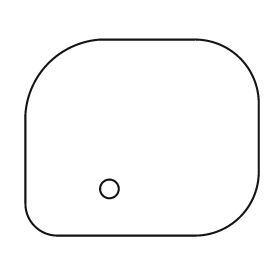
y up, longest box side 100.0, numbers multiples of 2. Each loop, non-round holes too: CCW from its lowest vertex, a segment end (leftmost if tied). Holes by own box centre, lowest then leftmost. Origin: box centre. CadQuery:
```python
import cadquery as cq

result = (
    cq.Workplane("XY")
    .moveTo(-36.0, -42.0)
    .lineTo(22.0, -42.0)
    .threePointArc((42.0, -34.0), (50.0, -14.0))
    .lineTo(50.0, 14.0)
    .threePointArc((42.0, 34.0), (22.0, 42.0))
    .lineTo(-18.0, 42.0)
    .threePointArc((-40.0, 32.0), (-50.0, 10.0))
    .lineTo(-50.0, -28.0)
    .threePointArc((-46.0, -38.0), (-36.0, -42.0))
    .close()
    .moveTo(-14.0, -22.0)
    .circle(4.0)
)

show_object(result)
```